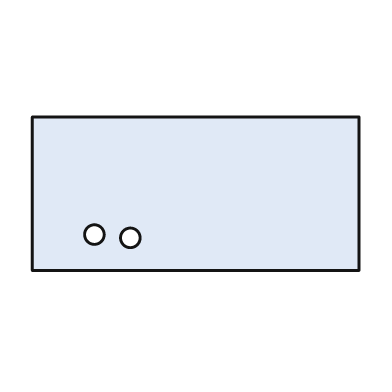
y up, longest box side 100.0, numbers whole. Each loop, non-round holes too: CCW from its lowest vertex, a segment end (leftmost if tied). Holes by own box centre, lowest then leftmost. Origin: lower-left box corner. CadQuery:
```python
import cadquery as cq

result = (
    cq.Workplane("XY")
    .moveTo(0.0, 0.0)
    .lineTo(100.0, 0.0)
    .lineTo(100.0, 47.0)
    .lineTo(0.0, 47.0)
    .close()
    .moveTo(30.0, 10.0)
    .circle(3.0)
    .moveTo(19.0, 11.0)
    .circle(3.0)
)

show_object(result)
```